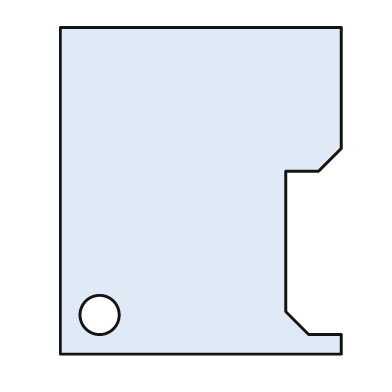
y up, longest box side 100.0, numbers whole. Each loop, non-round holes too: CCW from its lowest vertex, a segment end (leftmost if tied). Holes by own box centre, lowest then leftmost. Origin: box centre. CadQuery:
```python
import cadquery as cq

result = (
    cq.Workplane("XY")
    .moveTo(-43.0, -50.0)
    .lineTo(43.0, -50.0)
    .lineTo(43.0, -44.0)
    .lineTo(33.0, -44.0)
    .lineTo(26.0, -37.0)
    .lineTo(26.0, 6.0)
    .lineTo(36.0, 6.0)
    .lineTo(43.0, 13.0)
    .lineTo(43.0, 50.0)
    .lineTo(-43.0, 50.0)
    .close()
    .moveTo(-31.0, -38.0)
    .circle(6.0)
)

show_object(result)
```